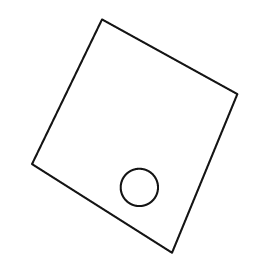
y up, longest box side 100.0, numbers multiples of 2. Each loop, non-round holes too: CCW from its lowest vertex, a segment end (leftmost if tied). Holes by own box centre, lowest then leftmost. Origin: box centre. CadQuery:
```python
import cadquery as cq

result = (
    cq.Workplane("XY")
    .moveTo(16.0, -50.0)
    .lineTo(44.0, 18.0)
    .lineTo(-14.0, 50.0)
    .lineTo(-44.0, -12.0)
    .close()
    .moveTo(2.0, -22.0)
    .circle(8.0)
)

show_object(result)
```